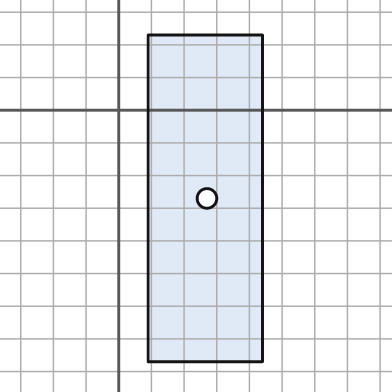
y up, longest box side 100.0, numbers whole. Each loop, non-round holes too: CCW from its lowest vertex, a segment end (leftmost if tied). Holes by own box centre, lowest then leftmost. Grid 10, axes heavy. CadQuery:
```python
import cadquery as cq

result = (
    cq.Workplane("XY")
    .moveTo(9.0, -77.0)
    .lineTo(44.0, -77.0)
    .lineTo(44.0, 23.0)
    .lineTo(9.0, 23.0)
    .close()
    .moveTo(27.0, -27.0)
    .circle(3.0)
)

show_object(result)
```